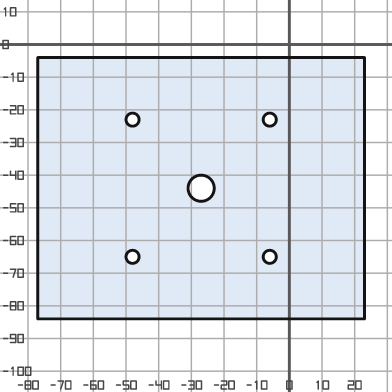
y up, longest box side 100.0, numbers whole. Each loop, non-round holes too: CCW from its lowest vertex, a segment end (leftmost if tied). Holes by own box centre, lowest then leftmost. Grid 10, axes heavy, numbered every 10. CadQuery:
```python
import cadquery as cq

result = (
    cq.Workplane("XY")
    .moveTo(-77.0, -84.0)
    .lineTo(23.0, -84.0)
    .lineTo(23.0, -4.0)
    .lineTo(-77.0, -4.0)
    .close()
    .moveTo(-48.0, -65.0)
    .circle(2.0)
    .moveTo(-6.0, -65.0)
    .circle(2.0)
    .moveTo(-27.0, -44.0)
    .circle(4.0)
    .moveTo(-48.0, -23.0)
    .circle(2.0)
    .moveTo(-6.0, -23.0)
    .circle(2.0)
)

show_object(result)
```